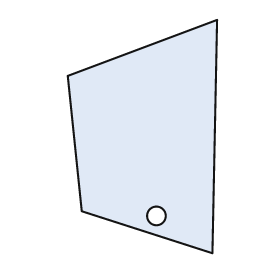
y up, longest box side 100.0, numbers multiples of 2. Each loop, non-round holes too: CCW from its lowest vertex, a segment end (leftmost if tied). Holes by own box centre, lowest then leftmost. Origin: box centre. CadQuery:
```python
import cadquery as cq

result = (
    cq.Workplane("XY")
    .moveTo(30.0, -50.0)
    .lineTo(32.0, 50.0)
    .lineTo(-32.0, 26.0)
    .lineTo(-26.0, -32.0)
    .close()
    .moveTo(6.0, -34.0)
    .circle(4.0)
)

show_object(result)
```